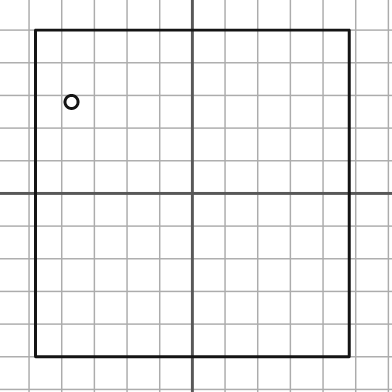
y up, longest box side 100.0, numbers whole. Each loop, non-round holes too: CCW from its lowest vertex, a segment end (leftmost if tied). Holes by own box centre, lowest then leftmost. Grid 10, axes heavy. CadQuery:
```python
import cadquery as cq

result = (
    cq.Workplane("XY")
    .moveTo(-48.0, -50.0)
    .lineTo(48.0, -50.0)
    .lineTo(48.0, 50.0)
    .lineTo(-48.0, 50.0)
    .close()
    .moveTo(-37.0, 28.0)
    .circle(2.0)
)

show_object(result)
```